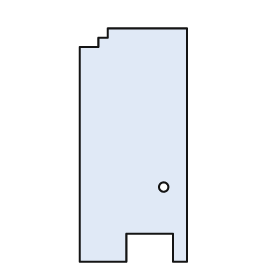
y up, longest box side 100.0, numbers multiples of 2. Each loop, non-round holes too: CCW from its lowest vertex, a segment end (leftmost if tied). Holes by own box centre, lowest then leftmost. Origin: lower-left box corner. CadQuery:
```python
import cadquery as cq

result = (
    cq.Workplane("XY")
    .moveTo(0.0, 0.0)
    .lineTo(20.0, 0.0)
    .lineTo(20.0, 12.0)
    .lineTo(40.0, 12.0)
    .lineTo(40.0, 0.0)
    .lineTo(46.0, 0.0)
    .lineTo(46.0, 100.0)
    .lineTo(12.0, 100.0)
    .lineTo(12.0, 96.0)
    .lineTo(8.0, 96.0)
    .lineTo(8.0, 92.0)
    .lineTo(0.0, 92.0)
    .close()
    .moveTo(36.0, 32.0)
    .circle(2.0)
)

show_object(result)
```